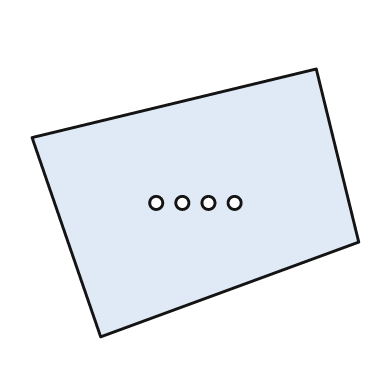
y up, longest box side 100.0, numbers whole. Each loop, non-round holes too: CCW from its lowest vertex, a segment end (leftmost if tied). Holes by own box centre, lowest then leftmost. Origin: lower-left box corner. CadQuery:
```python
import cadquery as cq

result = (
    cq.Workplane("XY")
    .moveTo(21.0, 0.0)
    .lineTo(100.0, 29.0)
    .lineTo(87.0, 82.0)
    .lineTo(0.0, 61.0)
    .close()
    .moveTo(38.0, 41.0)
    .circle(2.0)
    .moveTo(46.0, 41.0)
    .circle(2.0)
    .moveTo(54.0, 41.0)
    .circle(2.0)
    .moveTo(62.0, 41.0)
    .circle(2.0)
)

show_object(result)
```